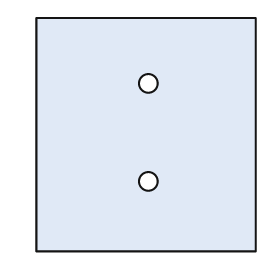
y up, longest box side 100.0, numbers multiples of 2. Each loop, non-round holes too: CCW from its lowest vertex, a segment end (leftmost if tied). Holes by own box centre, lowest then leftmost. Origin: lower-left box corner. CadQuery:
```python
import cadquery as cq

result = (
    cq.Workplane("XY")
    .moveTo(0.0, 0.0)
    .lineTo(94.0, 0.0)
    .lineTo(94.0, 100.0)
    .lineTo(0.0, 100.0)
    .close()
    .moveTo(48.0, 30.0)
    .circle(4.0)
    .moveTo(48.0, 72.0)
    .circle(4.0)
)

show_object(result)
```